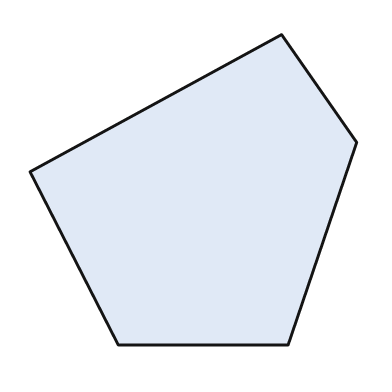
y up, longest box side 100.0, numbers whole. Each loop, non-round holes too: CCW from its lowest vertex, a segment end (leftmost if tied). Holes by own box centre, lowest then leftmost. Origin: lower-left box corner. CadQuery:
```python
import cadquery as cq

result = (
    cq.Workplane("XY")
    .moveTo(27.0, 0.0)
    .lineTo(79.0, 0.0)
    .lineTo(100.0, 62.0)
    .lineTo(77.0, 95.0)
    .lineTo(0.0, 53.0)
    .close()
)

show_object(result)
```